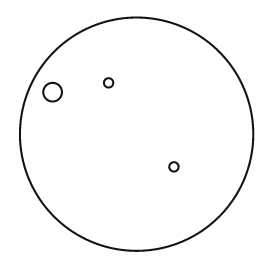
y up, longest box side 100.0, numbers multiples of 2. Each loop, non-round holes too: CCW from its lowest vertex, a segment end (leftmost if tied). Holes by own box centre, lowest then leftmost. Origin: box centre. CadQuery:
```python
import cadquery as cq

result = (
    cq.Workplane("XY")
    .moveTo(0.0, 0.0)
    .circle(50.0)
    .moveTo(16.0, -14.0)
    .circle(2.0)
    .moveTo(-36.0, 18.0)
    .circle(4.0)
    .moveTo(-12.0, 22.0)
    .circle(2.0)
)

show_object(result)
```